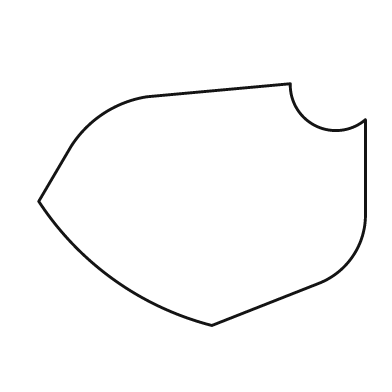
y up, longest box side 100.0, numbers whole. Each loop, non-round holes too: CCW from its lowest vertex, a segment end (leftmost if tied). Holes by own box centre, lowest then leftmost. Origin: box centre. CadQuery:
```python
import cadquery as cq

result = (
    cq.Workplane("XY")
    .moveTo(3.0, -37.0)
    .lineTo(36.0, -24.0)
    .threePointArc((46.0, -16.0), (50.0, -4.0))
    .lineTo(50.0, 26.0)
    .threePointArc((35.0, 24.0), (27.0, 37.0))
    .lineTo(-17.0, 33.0)
    .threePointArc((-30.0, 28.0), (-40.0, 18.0))
    .lineTo(-50.0, 1.0)
    .threePointArc((-27.0, -23.0), (3.0, -37.0))
    .close()
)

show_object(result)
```